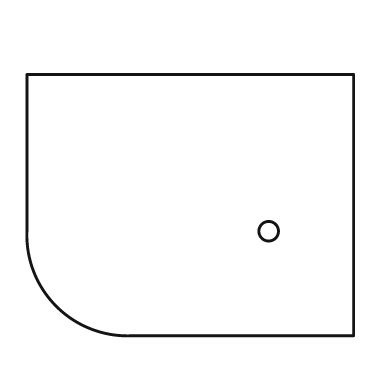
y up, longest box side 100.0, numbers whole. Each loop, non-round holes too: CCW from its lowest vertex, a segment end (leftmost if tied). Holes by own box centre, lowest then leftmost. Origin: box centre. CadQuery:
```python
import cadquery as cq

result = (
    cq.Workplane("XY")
    .moveTo(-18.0, -40.0)
    .lineTo(50.0, -40.0)
    .lineTo(50.0, 40.0)
    .lineTo(-50.0, 40.0)
    .lineTo(-50.0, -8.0)
    .threePointArc((-41.0, -31.0), (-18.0, -40.0))
    .close()
    .moveTo(24.0, -8.0)
    .circle(3.0)
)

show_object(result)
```